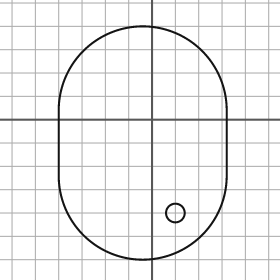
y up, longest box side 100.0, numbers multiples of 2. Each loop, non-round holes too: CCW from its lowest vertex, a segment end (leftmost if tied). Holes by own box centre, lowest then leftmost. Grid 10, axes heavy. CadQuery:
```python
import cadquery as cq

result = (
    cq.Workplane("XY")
    .moveTo(-40.0, -24.0)
    .threePointArc((-4.0, -60.0), (32.0, -24.0))
    .lineTo(32.0, 4.0)
    .threePointArc((-4.0, 40.0), (-40.0, 4.0))
    .close()
    .moveTo(10.0, -40.0)
    .circle(4.0)
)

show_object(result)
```